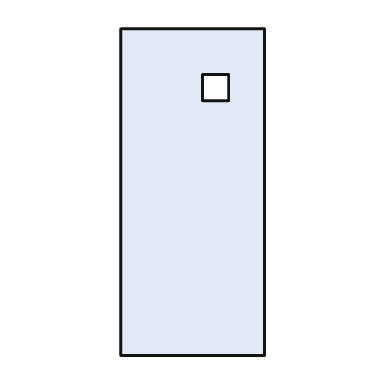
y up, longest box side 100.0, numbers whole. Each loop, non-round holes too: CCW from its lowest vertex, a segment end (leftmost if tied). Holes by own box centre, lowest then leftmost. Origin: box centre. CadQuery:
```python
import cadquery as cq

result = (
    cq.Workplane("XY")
    .moveTo(-22.0, -50.0)
    .lineTo(22.0, -50.0)
    .lineTo(22.0, 50.0)
    .lineTo(-22.0, 50.0)
    .close()
    .moveTo(3.0, 28.0)
    .lineTo(11.0, 28.0)
    .lineTo(11.0, 36.0)
    .lineTo(3.0, 36.0)
    .close()
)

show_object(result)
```